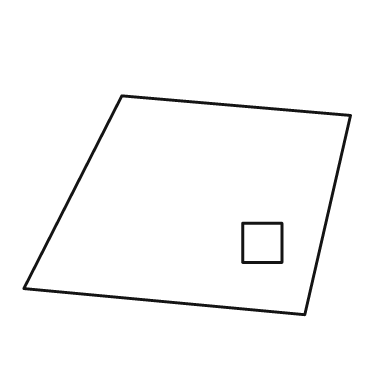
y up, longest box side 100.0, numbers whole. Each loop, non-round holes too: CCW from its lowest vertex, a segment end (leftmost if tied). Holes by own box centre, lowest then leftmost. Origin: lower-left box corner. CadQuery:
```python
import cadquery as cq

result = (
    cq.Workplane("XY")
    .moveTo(86.0, 0.0)
    .lineTo(100.0, 61.0)
    .lineTo(30.0, 67.0)
    .lineTo(0.0, 8.0)
    .close()
    .moveTo(67.0, 16.0)
    .lineTo(79.0, 16.0)
    .lineTo(79.0, 28.0)
    .lineTo(67.0, 28.0)
    .close()
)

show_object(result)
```